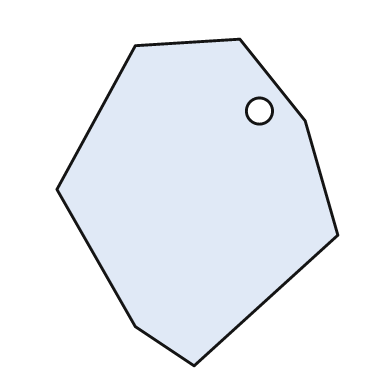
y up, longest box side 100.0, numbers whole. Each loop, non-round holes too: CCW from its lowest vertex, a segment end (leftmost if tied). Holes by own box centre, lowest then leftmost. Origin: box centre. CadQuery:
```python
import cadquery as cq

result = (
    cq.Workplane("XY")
    .moveTo(-1.0, -50.0)
    .lineTo(43.0, -10.0)
    .lineTo(33.0, 25.0)
    .lineTo(13.0, 50.0)
    .lineTo(-19.0, 48.0)
    .lineTo(-43.0, 4.0)
    .lineTo(-19.0, -38.0)
    .close()
    .moveTo(19.0, 28.0)
    .circle(4.0)
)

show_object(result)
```